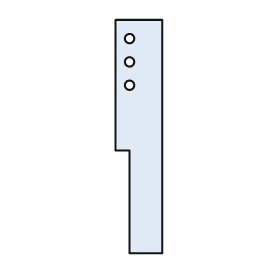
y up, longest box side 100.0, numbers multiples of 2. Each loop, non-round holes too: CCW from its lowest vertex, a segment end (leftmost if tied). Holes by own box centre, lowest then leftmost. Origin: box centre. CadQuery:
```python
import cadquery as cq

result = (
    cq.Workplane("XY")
    .moveTo(-4.0, -50.0)
    .lineTo(10.0, -50.0)
    .lineTo(10.0, 50.0)
    .lineTo(-10.0, 50.0)
    .lineTo(-10.0, -6.0)
    .lineTo(-4.0, -6.0)
    .close()
    .moveTo(-4.0, 22.0)
    .circle(2.0)
    .moveTo(-4.0, 32.0)
    .circle(2.0)
    .moveTo(-4.0, 42.0)
    .circle(2.0)
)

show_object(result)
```